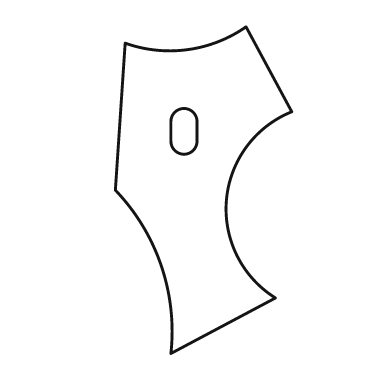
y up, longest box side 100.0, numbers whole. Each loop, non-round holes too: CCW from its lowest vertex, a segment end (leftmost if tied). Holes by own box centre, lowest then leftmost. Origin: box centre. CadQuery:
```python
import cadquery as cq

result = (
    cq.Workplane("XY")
    .moveTo(-10.0, -50.0)
    .lineTo(22.0, -33.0)
    .threePointArc((7.0, -3.0), (27.0, 24.0))
    .lineTo(13.0, 50.0)
    .threePointArc((-5.0, 43.0), (-24.0, 45.0))
    .lineTo(-27.0, 0.0)
    .threePointArc((-13.0, -23.0), (-10.0, -50.0))
    .close()
    .moveTo(-10.0, 15.0)
    .threePointArc((-6.0, 11.0), (-2.0, 15.0))
    .lineTo(-2.0, 21.0)
    .threePointArc((-6.0, 25.0), (-10.0, 21.0))
    .close()
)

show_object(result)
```